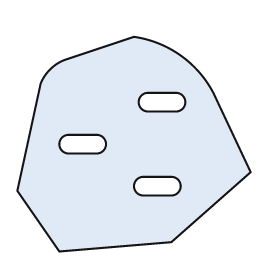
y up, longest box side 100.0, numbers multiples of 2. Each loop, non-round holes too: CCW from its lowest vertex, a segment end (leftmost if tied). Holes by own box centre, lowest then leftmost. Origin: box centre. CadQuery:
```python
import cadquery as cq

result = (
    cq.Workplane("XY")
    .moveTo(-32.0, -46.0)
    .lineTo(16.0, -42.0)
    .lineTo(50.0, -12.0)
    .lineTo(34.0, 22.0)
    .threePointArc((20.0, 38.0), (0.0, 46.0))
    .lineTo(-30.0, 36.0)
    .threePointArc((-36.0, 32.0), (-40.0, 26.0))
    .lineTo(-50.0, -20.0)
    .close()
    .moveTo(4.0, -22.0)
    .lineTo(16.0, -22.0)
    .threePointArc((20.0, -18.0), (16.0, -14.0))
    .lineTo(4.0, -14.0)
    .threePointArc((0.0, -18.0), (4.0, -22.0))
    .close()
    .moveTo(-28.0, -4.0)
    .lineTo(-16.0, -4.0)
    .threePointArc((-12.0, 0.0), (-16.0, 4.0))
    .lineTo(-28.0, 4.0)
    .threePointArc((-32.0, 0.0), (-28.0, -4.0))
    .close()
    .moveTo(6.0, 14.0)
    .lineTo(18.0, 14.0)
    .threePointArc((22.0, 18.0), (18.0, 22.0))
    .lineTo(6.0, 22.0)
    .threePointArc((2.0, 18.0), (6.0, 14.0))
    .close()
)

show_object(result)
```